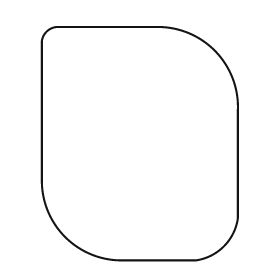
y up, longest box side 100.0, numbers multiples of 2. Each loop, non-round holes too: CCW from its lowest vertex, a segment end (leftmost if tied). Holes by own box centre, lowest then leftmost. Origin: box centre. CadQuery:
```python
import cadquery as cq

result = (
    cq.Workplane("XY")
    .moveTo(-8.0, -50.0)
    .lineTo(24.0, -50.0)
    .threePointArc((36.0, -44.0), (42.0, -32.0))
    .lineTo(42.0, 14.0)
    .threePointArc((32.0, 40.0), (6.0, 50.0))
    .lineTo(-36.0, 50.0)
    .threePointArc((-40.0, 48.0), (-42.0, 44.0))
    .lineTo(-42.0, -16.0)
    .threePointArc((-32.0, -40.0), (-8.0, -50.0))
    .close()
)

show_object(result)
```